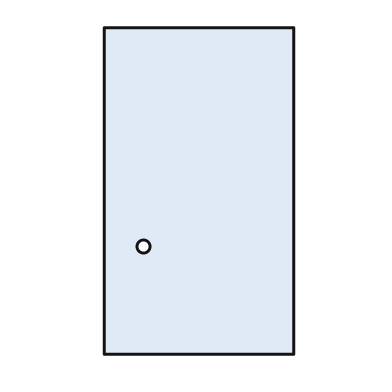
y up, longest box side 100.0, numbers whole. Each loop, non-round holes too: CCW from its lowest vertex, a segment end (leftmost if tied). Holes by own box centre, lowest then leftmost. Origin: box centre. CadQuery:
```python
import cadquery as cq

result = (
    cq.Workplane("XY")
    .moveTo(-29.0, -50.0)
    .lineTo(29.0, -50.0)
    .lineTo(29.0, 50.0)
    .lineTo(-29.0, 50.0)
    .close()
    .moveTo(-17.0, -17.0)
    .circle(2.0)
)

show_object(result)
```